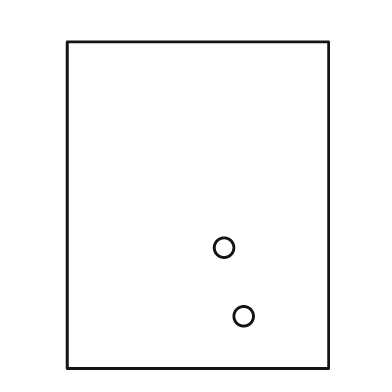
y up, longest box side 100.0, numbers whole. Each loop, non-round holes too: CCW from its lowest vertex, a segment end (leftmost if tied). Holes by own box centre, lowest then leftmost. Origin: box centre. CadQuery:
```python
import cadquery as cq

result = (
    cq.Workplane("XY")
    .moveTo(-40.0, -50.0)
    .lineTo(40.0, -50.0)
    .lineTo(40.0, 50.0)
    .lineTo(-40.0, 50.0)
    .close()
    .moveTo(14.0, -34.0)
    .circle(3.0)
    .moveTo(8.0, -13.0)
    .circle(3.0)
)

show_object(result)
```